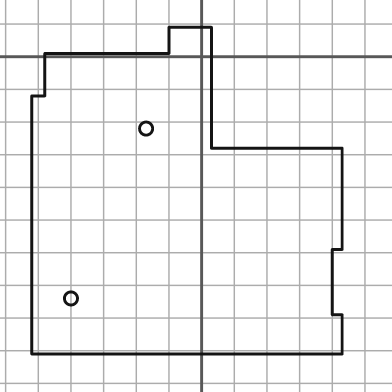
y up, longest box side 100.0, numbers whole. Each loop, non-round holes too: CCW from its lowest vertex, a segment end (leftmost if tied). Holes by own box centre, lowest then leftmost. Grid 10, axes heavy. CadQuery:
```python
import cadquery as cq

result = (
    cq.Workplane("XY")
    .moveTo(-52.0, -91.0)
    .lineTo(43.0, -91.0)
    .lineTo(43.0, -79.0)
    .lineTo(40.0, -79.0)
    .lineTo(40.0, -59.0)
    .lineTo(43.0, -59.0)
    .lineTo(43.0, -28.0)
    .lineTo(3.0, -28.0)
    .lineTo(3.0, 9.0)
    .lineTo(-10.0, 9.0)
    .lineTo(-10.0, 1.0)
    .lineTo(-48.0, 1.0)
    .lineTo(-48.0, -12.0)
    .lineTo(-52.0, -12.0)
    .close()
    .moveTo(-40.0, -74.0)
    .circle(2.0)
    .moveTo(-17.0, -22.0)
    .circle(2.0)
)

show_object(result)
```